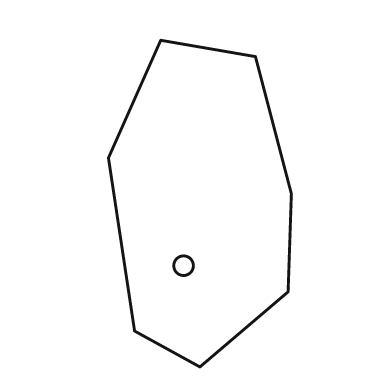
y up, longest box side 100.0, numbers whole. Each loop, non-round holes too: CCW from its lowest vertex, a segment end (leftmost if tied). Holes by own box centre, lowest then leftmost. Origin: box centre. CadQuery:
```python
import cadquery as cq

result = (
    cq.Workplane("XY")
    .moveTo(0.0, -50.0)
    .lineTo(27.0, -27.0)
    .lineTo(28.0, 3.0)
    .lineTo(17.0, 45.0)
    .lineTo(-12.0, 50.0)
    .lineTo(-28.0, 14.0)
    .lineTo(-20.0, -39.0)
    .close()
    .moveTo(-5.0, -19.0)
    .circle(3.0)
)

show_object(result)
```